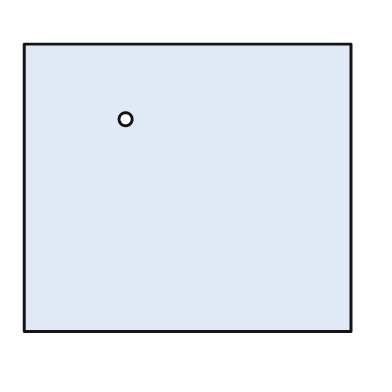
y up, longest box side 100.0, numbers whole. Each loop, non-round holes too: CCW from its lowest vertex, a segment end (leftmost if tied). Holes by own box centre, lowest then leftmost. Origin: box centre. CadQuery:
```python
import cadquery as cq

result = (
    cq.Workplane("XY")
    .moveTo(-50.0, -44.0)
    .lineTo(50.0, -44.0)
    .lineTo(50.0, 44.0)
    .lineTo(-50.0, 44.0)
    .close()
    .moveTo(-19.0, 21.0)
    .circle(2.0)
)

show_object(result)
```